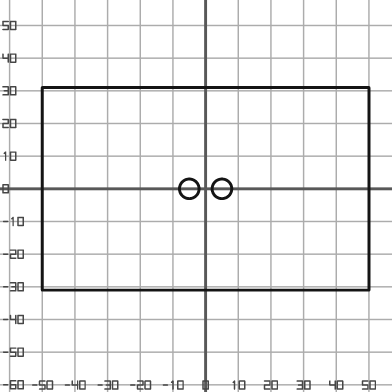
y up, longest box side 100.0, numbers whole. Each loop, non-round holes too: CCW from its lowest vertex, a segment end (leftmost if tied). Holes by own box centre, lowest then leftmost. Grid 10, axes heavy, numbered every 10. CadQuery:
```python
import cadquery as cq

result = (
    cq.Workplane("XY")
    .moveTo(-50.0, -31.0)
    .lineTo(50.0, -31.0)
    .lineTo(50.0, 31.0)
    .lineTo(-50.0, 31.0)
    .close()
    .moveTo(-5.0, 0.0)
    .circle(3.0)
    .moveTo(5.0, 0.0)
    .circle(3.0)
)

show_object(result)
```